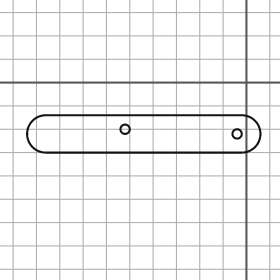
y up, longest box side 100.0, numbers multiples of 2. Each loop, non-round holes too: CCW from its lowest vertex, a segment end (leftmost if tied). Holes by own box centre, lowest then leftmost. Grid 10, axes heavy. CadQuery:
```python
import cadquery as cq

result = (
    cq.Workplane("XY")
    .moveTo(-86.0, -30.0)
    .lineTo(-2.0, -30.0)
    .threePointArc((6.0, -22.0), (-2.0, -14.0))
    .lineTo(-86.0, -14.0)
    .threePointArc((-94.0, -22.0), (-86.0, -30.0))
    .close()
    .moveTo(-4.0, -22.0)
    .circle(2.0)
    .moveTo(-52.0, -20.0)
    .circle(2.0)
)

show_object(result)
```